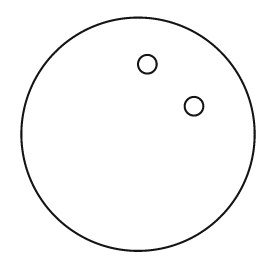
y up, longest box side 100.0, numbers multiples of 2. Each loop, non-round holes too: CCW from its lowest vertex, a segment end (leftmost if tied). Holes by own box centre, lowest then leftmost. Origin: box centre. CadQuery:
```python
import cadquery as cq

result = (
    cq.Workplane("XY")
    .moveTo(0.0, 0.0)
    .circle(50.0)
    .moveTo(24.0, 12.0)
    .circle(4.0)
    .moveTo(4.0, 30.0)
    .circle(4.0)
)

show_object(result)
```